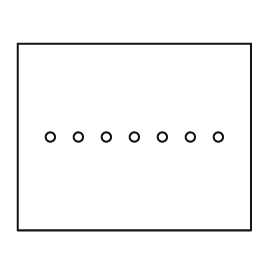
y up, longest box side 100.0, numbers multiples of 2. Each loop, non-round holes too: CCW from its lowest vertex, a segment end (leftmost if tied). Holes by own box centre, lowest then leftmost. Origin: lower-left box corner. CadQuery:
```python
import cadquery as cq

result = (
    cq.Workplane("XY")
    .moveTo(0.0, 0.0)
    .lineTo(100.0, 0.0)
    .lineTo(100.0, 80.0)
    .lineTo(0.0, 80.0)
    .close()
    .moveTo(14.0, 40.0)
    .circle(2.0)
    .moveTo(26.0, 40.0)
    .circle(2.0)
    .moveTo(38.0, 40.0)
    .circle(2.0)
    .moveTo(50.0, 40.0)
    .circle(2.0)
    .moveTo(62.0, 40.0)
    .circle(2.0)
    .moveTo(74.0, 40.0)
    .circle(2.0)
    .moveTo(86.0, 40.0)
    .circle(2.0)
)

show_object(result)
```